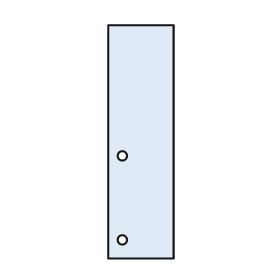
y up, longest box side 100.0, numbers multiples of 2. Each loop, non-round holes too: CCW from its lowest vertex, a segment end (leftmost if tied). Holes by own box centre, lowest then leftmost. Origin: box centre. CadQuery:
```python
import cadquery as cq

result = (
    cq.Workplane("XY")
    .moveTo(-14.0, -50.0)
    .lineTo(14.0, -50.0)
    .lineTo(14.0, 50.0)
    .lineTo(-14.0, 50.0)
    .close()
    .moveTo(-8.0, -42.0)
    .circle(2.0)
    .moveTo(-8.0, -6.0)
    .circle(2.0)
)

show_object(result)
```